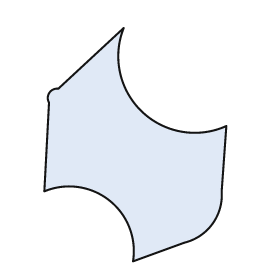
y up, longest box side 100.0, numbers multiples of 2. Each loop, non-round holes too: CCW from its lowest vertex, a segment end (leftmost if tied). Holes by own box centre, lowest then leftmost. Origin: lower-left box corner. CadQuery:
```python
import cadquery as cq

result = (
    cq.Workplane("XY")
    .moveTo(38.0, 0.0)
    .lineTo(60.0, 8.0)
    .threePointArc((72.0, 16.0), (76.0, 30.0))
    .lineTo(78.0, 58.0)
    .threePointArc((42.0, 64.0), (34.0, 100.0))
    .lineTo(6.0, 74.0)
    .threePointArc((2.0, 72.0), (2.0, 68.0))
    .lineTo(0.0, 30.0)
    .threePointArc((28.0, 26.0), (38.0, 0.0))
    .close()
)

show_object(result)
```